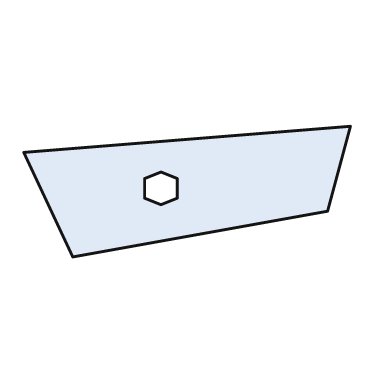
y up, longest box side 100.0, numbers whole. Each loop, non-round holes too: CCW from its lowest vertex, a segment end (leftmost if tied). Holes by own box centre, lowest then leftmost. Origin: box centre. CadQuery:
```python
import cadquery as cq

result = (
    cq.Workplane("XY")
    .moveTo(-35.0, -20.0)
    .lineTo(43.0, -6.0)
    .lineTo(50.0, 20.0)
    .lineTo(-50.0, 12.0)
    .close()
    .moveTo(-8.0, -4.0)
    .lineTo(-3.0, -2.0)
    .lineTo(-3.0, 4.0)
    .lineTo(-8.0, 6.0)
    .lineTo(-13.0, 4.0)
    .lineTo(-13.0, -2.0)
    .close()
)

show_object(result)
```